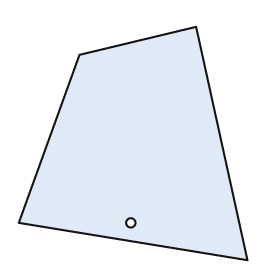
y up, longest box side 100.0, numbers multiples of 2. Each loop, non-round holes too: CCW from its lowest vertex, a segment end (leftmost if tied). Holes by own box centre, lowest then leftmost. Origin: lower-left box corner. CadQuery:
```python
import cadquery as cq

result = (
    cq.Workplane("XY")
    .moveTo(98.0, 0.0)
    .lineTo(76.0, 100.0)
    .lineTo(26.0, 88.0)
    .lineTo(0.0, 16.0)
    .close()
    .moveTo(48.0, 16.0)
    .circle(2.0)
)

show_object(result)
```